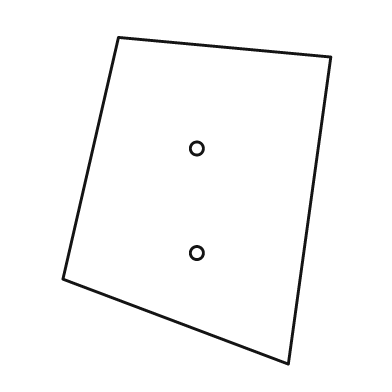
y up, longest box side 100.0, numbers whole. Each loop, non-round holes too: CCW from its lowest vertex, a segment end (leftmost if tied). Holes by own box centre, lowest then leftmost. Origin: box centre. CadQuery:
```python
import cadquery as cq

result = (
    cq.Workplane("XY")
    .moveTo(28.0, -50.0)
    .lineTo(41.0, 44.0)
    .lineTo(-24.0, 50.0)
    .lineTo(-41.0, -24.0)
    .close()
    .moveTo(0.0, -16.0)
    .circle(2.0)
    .moveTo(0.0, 16.0)
    .circle(2.0)
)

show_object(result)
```